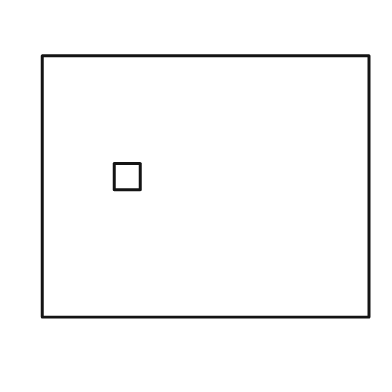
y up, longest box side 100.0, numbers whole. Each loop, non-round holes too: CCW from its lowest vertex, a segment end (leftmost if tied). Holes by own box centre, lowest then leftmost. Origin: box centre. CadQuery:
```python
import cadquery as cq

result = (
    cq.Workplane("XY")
    .moveTo(-50.0, -40.0)
    .lineTo(50.0, -40.0)
    .lineTo(50.0, 40.0)
    .lineTo(-50.0, 40.0)
    .close()
    .moveTo(-28.0, -1.0)
    .lineTo(-20.0, -1.0)
    .lineTo(-20.0, 7.0)
    .lineTo(-28.0, 7.0)
    .close()
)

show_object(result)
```